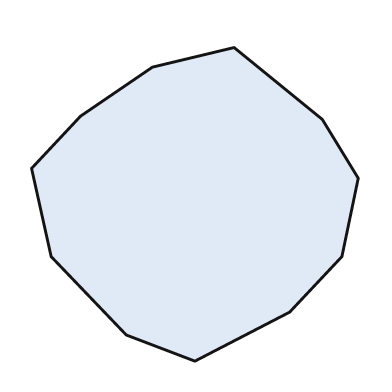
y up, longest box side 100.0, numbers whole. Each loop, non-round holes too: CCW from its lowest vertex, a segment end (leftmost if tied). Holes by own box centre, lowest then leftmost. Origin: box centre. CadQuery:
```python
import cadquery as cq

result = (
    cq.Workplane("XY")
    .moveTo(0.0, -48.0)
    .lineTo(29.0, -33.0)
    .lineTo(45.0, -16.0)
    .lineTo(50.0, 8.0)
    .lineTo(39.0, 26.0)
    .lineTo(12.0, 48.0)
    .lineTo(-13.0, 42.0)
    .lineTo(-35.0, 27.0)
    .lineTo(-50.0, 11.0)
    .lineTo(-44.0, -16.0)
    .lineTo(-21.0, -40.0)
    .close()
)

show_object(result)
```